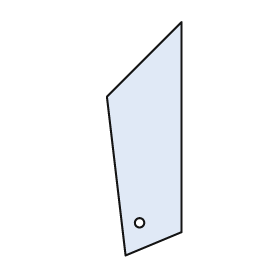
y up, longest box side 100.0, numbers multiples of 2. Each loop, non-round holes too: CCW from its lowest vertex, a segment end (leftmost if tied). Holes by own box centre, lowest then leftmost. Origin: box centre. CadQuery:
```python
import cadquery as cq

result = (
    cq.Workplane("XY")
    .moveTo(-8.0, -50.0)
    .lineTo(16.0, -40.0)
    .lineTo(16.0, 50.0)
    .lineTo(-16.0, 18.0)
    .close()
    .moveTo(-2.0, -36.0)
    .circle(2.0)
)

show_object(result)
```